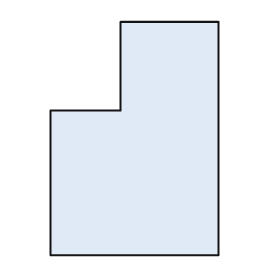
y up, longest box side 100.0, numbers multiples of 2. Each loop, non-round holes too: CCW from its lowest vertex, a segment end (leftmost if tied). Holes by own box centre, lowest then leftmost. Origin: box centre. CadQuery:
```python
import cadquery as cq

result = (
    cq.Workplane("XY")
    .moveTo(-36.0, -50.0)
    .lineTo(36.0, -50.0)
    .lineTo(36.0, 50.0)
    .lineTo(-6.0, 50.0)
    .lineTo(-6.0, 12.0)
    .lineTo(-36.0, 12.0)
    .close()
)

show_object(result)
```